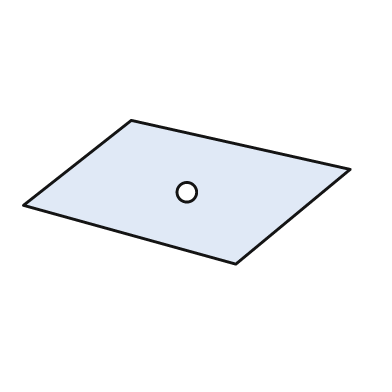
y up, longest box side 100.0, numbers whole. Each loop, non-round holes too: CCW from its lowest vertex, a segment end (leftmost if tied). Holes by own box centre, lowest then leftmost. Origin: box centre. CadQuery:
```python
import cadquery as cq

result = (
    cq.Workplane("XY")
    .moveTo(15.0, -22.0)
    .lineTo(50.0, 7.0)
    .lineTo(-17.0, 22.0)
    .lineTo(-50.0, -4.0)
    .close()
    .moveTo(0.0, 0.0)
    .circle(3.0)
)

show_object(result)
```